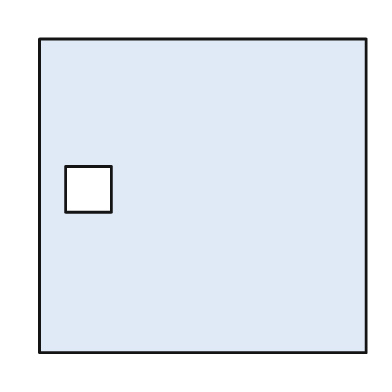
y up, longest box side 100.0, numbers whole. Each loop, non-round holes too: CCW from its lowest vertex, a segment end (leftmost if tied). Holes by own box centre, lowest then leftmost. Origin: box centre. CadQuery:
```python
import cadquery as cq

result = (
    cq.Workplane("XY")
    .moveTo(-50.0, -48.0)
    .lineTo(50.0, -48.0)
    .lineTo(50.0, 48.0)
    .lineTo(-50.0, 48.0)
    .close()
    .moveTo(-42.0, -5.0)
    .lineTo(-28.0, -5.0)
    .lineTo(-28.0, 9.0)
    .lineTo(-42.0, 9.0)
    .close()
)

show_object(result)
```